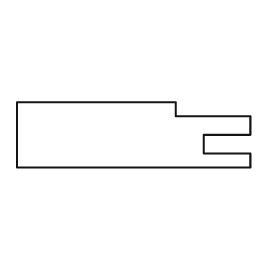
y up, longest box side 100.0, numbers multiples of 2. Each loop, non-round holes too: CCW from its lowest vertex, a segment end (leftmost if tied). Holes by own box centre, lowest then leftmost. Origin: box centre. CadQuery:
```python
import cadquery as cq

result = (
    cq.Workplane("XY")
    .moveTo(-50.0, -14.0)
    .lineTo(50.0, -14.0)
    .lineTo(50.0, -8.0)
    .lineTo(30.0, -8.0)
    .lineTo(30.0, 0.0)
    .lineTo(50.0, 0.0)
    .lineTo(50.0, 8.0)
    .lineTo(18.0, 8.0)
    .lineTo(18.0, 14.0)
    .lineTo(-50.0, 14.0)
    .close()
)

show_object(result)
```